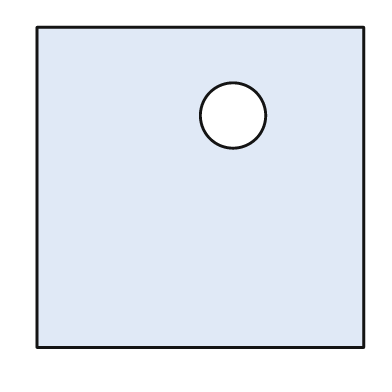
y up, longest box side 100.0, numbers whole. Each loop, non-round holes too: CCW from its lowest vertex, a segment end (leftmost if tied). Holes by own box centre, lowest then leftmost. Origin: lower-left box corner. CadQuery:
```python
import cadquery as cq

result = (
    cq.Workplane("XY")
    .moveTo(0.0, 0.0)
    .lineTo(100.0, 0.0)
    .lineTo(100.0, 98.0)
    .lineTo(0.0, 98.0)
    .close()
    .moveTo(60.0, 71.0)
    .circle(10.0)
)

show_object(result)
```